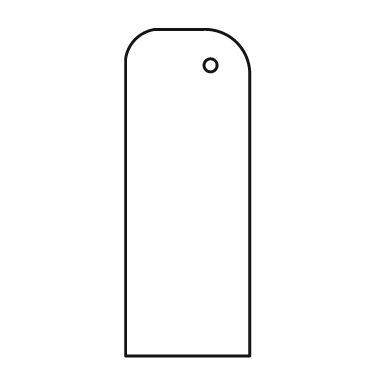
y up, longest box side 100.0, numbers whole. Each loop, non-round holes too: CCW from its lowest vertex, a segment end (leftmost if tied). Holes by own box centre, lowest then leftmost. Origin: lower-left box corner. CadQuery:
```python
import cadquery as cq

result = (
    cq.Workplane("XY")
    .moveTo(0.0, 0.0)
    .lineTo(38.0, 0.0)
    .lineTo(38.0, 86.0)
    .threePointArc((34.0, 96.0), (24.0, 100.0))
    .lineTo(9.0, 100.0)
    .threePointArc((3.0, 97.0), (0.0, 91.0))
    .close()
    .moveTo(26.0, 89.0)
    .circle(2.0)
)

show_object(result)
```